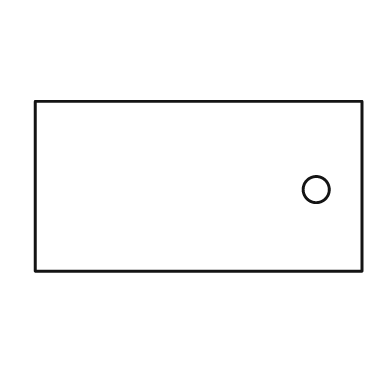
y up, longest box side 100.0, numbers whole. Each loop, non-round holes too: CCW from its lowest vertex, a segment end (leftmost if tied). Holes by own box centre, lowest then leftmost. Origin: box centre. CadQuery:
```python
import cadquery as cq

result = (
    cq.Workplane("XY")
    .moveTo(-50.0, -26.0)
    .lineTo(50.0, -26.0)
    .lineTo(50.0, 26.0)
    .lineTo(-50.0, 26.0)
    .close()
    .moveTo(36.0, -1.0)
    .circle(4.0)
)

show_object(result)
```